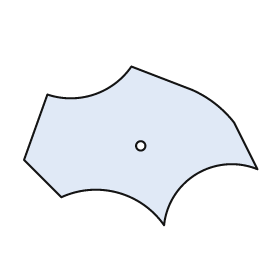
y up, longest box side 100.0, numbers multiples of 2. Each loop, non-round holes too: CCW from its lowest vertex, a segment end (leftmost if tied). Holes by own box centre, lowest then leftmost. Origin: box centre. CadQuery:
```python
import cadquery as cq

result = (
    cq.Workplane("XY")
    .moveTo(10.0, -34.0)
    .threePointArc((24.0, -12.0), (50.0, -10.0))
    .lineTo(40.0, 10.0)
    .threePointArc((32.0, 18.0), (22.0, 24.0))
    .lineTo(-4.0, 34.0)
    .threePointArc((-20.0, 22.0), (-40.0, 22.0))
    .lineTo(-50.0, -6.0)
    .lineTo(-34.0, -22.0)
    .threePointArc((-10.0, -20.0), (10.0, -34.0))
    .close()
    .moveTo(0.0, 0.0)
    .circle(2.0)
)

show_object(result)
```